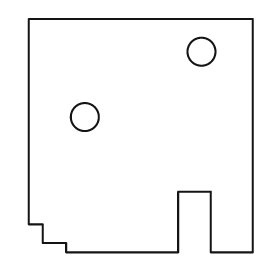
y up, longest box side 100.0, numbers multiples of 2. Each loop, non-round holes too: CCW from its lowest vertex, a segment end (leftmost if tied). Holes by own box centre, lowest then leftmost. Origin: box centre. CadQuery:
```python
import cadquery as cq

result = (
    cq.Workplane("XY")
    .moveTo(-32.0, -50.0)
    .lineTo(16.0, -50.0)
    .lineTo(16.0, -24.0)
    .lineTo(30.0, -24.0)
    .lineTo(30.0, -50.0)
    .lineTo(48.0, -50.0)
    .lineTo(48.0, 50.0)
    .lineTo(-48.0, 50.0)
    .lineTo(-48.0, -38.0)
    .lineTo(-42.0, -38.0)
    .lineTo(-42.0, -46.0)
    .lineTo(-32.0, -46.0)
    .close()
    .moveTo(-24.0, 8.0)
    .circle(6.0)
    .moveTo(26.0, 36.0)
    .circle(6.0)
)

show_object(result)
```